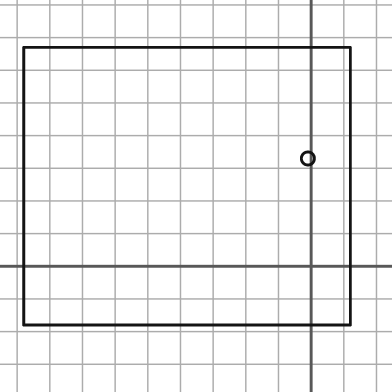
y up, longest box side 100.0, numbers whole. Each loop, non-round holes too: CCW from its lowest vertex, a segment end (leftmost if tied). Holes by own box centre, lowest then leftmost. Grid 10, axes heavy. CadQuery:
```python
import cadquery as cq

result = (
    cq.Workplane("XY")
    .moveTo(-88.0, -18.0)
    .lineTo(12.0, -18.0)
    .lineTo(12.0, 67.0)
    .lineTo(-88.0, 67.0)
    .close()
    .moveTo(-1.0, 33.0)
    .circle(2.0)
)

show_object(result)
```